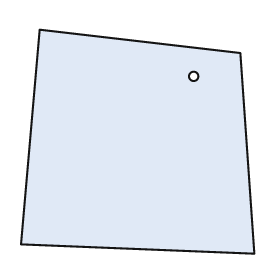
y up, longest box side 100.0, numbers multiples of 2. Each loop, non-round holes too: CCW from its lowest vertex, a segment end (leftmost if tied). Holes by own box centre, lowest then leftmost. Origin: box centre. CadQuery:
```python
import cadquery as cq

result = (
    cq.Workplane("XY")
    .moveTo(50.0, -48.0)
    .lineTo(44.0, 38.0)
    .lineTo(-42.0, 48.0)
    .lineTo(-50.0, -44.0)
    .close()
    .moveTo(24.0, 28.0)
    .circle(2.0)
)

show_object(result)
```